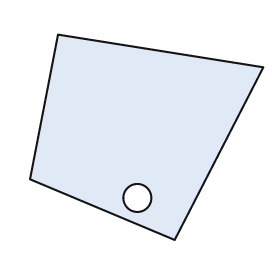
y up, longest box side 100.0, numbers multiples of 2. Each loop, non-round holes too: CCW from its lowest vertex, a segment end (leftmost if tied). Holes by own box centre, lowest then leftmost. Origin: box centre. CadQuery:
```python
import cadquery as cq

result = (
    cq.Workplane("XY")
    .moveTo(12.0, -44.0)
    .lineTo(50.0, 30.0)
    .lineTo(-38.0, 44.0)
    .lineTo(-50.0, -18.0)
    .close()
    .moveTo(-4.0, -26.0)
    .circle(6.0)
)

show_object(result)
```